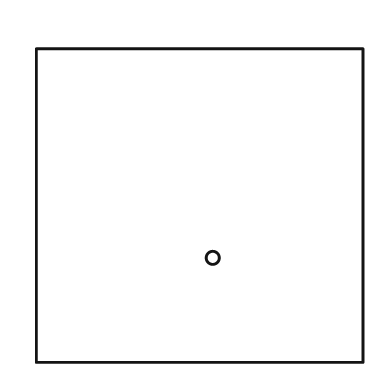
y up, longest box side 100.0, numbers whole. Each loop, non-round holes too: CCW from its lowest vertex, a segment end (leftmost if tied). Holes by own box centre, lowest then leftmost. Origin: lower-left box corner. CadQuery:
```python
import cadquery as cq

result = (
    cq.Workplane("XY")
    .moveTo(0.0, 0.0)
    .lineTo(100.0, 0.0)
    .lineTo(100.0, 96.0)
    .lineTo(0.0, 96.0)
    .close()
    .moveTo(54.0, 32.0)
    .circle(2.0)
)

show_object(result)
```